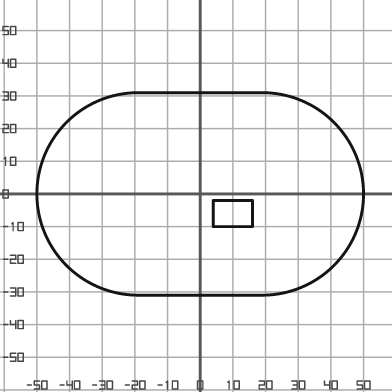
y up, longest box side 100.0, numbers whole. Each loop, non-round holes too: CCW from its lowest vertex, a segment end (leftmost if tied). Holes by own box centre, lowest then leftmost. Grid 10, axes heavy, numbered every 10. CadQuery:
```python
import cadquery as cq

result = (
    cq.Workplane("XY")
    .moveTo(-19.0, -31.0)
    .lineTo(19.0, -31.0)
    .threePointArc((50.0, 0.0), (19.0, 31.0))
    .lineTo(-19.0, 31.0)
    .threePointArc((-50.0, 0.0), (-19.0, -31.0))
    .close()
    .moveTo(4.0, -10.0)
    .lineTo(16.0, -10.0)
    .lineTo(16.0, -2.0)
    .lineTo(4.0, -2.0)
    .close()
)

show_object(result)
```